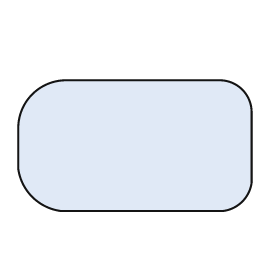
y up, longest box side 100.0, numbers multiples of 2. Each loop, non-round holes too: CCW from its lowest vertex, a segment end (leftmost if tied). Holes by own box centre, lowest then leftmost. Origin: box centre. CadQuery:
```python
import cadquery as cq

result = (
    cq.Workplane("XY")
    .moveTo(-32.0, -28.0)
    .lineTo(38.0, -28.0)
    .threePointArc((46.0, -24.0), (50.0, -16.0))
    .lineTo(50.0, 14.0)
    .threePointArc((46.0, 24.0), (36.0, 28.0))
    .lineTo(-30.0, 28.0)
    .threePointArc((-44.0, 22.0), (-50.0, 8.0))
    .lineTo(-50.0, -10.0)
    .threePointArc((-44.0, -22.0), (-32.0, -28.0))
    .close()
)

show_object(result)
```